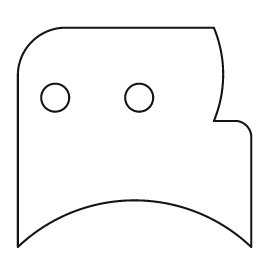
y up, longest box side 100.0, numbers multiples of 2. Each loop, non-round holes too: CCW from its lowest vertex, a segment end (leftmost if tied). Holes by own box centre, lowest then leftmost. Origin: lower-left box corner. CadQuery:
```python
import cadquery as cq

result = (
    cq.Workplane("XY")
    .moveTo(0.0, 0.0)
    .threePointArc((50.0, 20.0), (100.0, 0.0))
    .lineTo(100.0, 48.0)
    .threePointArc((98.0, 52.0), (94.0, 54.0))
    .lineTo(84.0, 54.0)
    .threePointArc((88.0, 74.0), (84.0, 94.0))
    .lineTo(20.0, 94.0)
    .threePointArc((6.0, 88.0), (0.0, 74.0))
    .close()
    .moveTo(16.0, 64.0)
    .circle(6.0)
    .moveTo(52.0, 64.0)
    .circle(6.0)
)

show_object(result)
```